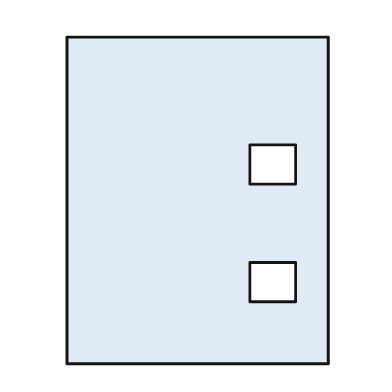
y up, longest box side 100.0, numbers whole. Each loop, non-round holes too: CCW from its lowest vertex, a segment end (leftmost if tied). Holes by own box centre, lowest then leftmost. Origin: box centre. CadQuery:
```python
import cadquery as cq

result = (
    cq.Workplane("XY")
    .moveTo(-40.0, -50.0)
    .lineTo(40.0, -50.0)
    .lineTo(40.0, 50.0)
    .lineTo(-40.0, 50.0)
    .close()
    .moveTo(16.0, -31.0)
    .lineTo(30.0, -31.0)
    .lineTo(30.0, -19.0)
    .lineTo(16.0, -19.0)
    .close()
    .moveTo(16.0, 5.0)
    .lineTo(30.0, 5.0)
    .lineTo(30.0, 17.0)
    .lineTo(16.0, 17.0)
    .close()
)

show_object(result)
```